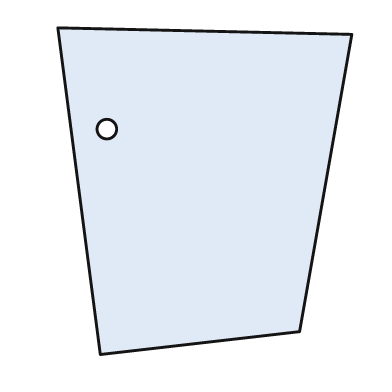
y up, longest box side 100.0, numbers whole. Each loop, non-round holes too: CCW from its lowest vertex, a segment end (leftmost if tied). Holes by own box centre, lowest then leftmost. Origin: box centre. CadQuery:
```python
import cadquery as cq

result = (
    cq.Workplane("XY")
    .moveTo(-32.0, -50.0)
    .lineTo(29.0, -43.0)
    .lineTo(45.0, 48.0)
    .lineTo(-45.0, 50.0)
    .close()
    .moveTo(-30.0, 19.0)
    .circle(3.0)
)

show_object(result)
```